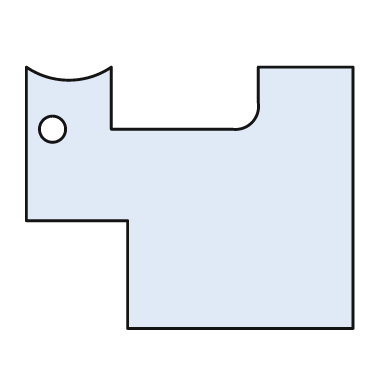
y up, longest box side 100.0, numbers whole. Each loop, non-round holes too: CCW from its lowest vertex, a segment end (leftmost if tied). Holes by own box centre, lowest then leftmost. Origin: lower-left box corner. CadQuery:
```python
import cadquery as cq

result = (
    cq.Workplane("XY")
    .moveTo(31.0, 0.0)
    .lineTo(100.0, 0.0)
    .lineTo(100.0, 80.0)
    .lineTo(71.0, 80.0)
    .lineTo(71.0, 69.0)
    .threePointArc((69.0, 63.0), (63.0, 61.0))
    .lineTo(26.0, 61.0)
    .lineTo(26.0, 80.0)
    .threePointArc((13.0, 76.0), (0.0, 80.0))
    .lineTo(0.0, 33.0)
    .lineTo(31.0, 33.0)
    .close()
    .moveTo(8.0, 61.0)
    .circle(4.0)
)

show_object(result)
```